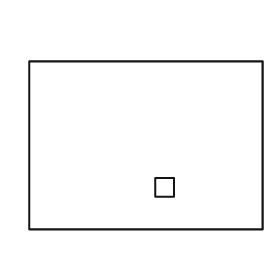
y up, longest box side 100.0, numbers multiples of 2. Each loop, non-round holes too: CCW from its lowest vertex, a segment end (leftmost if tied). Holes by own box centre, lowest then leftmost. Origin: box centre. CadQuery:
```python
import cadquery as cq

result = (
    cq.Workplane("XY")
    .moveTo(-50.0, -36.0)
    .lineTo(50.0, -36.0)
    .lineTo(50.0, 36.0)
    .lineTo(-50.0, 36.0)
    .close()
    .moveTo(4.0, -22.0)
    .lineTo(12.0, -22.0)
    .lineTo(12.0, -14.0)
    .lineTo(4.0, -14.0)
    .close()
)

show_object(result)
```